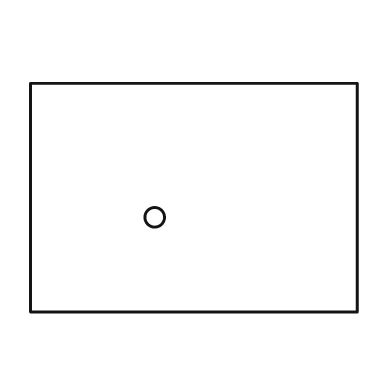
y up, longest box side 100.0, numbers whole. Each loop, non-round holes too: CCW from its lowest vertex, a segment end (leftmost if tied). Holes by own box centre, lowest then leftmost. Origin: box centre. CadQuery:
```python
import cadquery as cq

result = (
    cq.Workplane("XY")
    .moveTo(-50.0, -35.0)
    .lineTo(50.0, -35.0)
    .lineTo(50.0, 35.0)
    .lineTo(-50.0, 35.0)
    .close()
    .moveTo(-12.0, -6.0)
    .circle(3.0)
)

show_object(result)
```